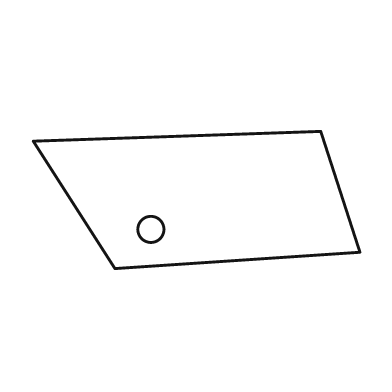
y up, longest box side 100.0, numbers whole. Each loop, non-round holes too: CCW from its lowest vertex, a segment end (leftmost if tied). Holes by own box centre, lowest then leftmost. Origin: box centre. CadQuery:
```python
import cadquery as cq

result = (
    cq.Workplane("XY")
    .moveTo(-25.0, -21.0)
    .lineTo(50.0, -16.0)
    .lineTo(38.0, 21.0)
    .lineTo(-50.0, 18.0)
    .close()
    .moveTo(-14.0, -9.0)
    .circle(4.0)
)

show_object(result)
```